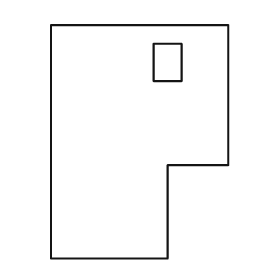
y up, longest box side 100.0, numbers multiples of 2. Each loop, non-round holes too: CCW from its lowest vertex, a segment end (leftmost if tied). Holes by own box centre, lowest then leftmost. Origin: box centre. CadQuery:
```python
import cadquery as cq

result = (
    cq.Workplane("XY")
    .moveTo(-38.0, -50.0)
    .lineTo(12.0, -50.0)
    .lineTo(12.0, -10.0)
    .lineTo(38.0, -10.0)
    .lineTo(38.0, 50.0)
    .lineTo(-38.0, 50.0)
    .close()
    .moveTo(6.0, 26.0)
    .lineTo(18.0, 26.0)
    .lineTo(18.0, 42.0)
    .lineTo(6.0, 42.0)
    .close()
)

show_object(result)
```